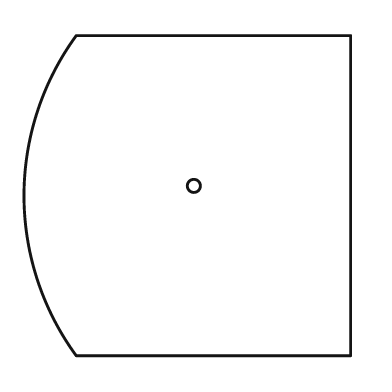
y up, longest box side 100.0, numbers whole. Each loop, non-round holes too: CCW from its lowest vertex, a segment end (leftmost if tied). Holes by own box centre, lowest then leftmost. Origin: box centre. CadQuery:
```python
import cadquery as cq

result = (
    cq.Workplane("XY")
    .moveTo(-34.0, -49.0)
    .lineTo(50.0, -49.0)
    .lineTo(50.0, 49.0)
    .lineTo(-34.0, 49.0)
    .threePointArc((-50.0, 0.0), (-34.0, -49.0))
    .close()
    .moveTo(2.0, 3.0)
    .circle(2.0)
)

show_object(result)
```